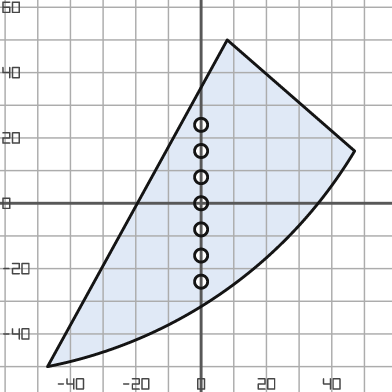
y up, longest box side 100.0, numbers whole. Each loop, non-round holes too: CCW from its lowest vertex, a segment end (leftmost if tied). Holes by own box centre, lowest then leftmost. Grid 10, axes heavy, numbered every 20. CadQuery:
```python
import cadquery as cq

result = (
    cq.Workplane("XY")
    .moveTo(-47.0, -50.0)
    .threePointArc((7.0, -27.0), (47.0, 16.0))
    .lineTo(8.0, 50.0)
    .close()
    .moveTo(0.0, -24.0)
    .circle(2.0)
    .moveTo(0.0, -16.0)
    .circle(2.0)
    .moveTo(0.0, -8.0)
    .circle(2.0)
    .moveTo(0.0, 0.0)
    .circle(2.0)
    .moveTo(0.0, 8.0)
    .circle(2.0)
    .moveTo(0.0, 16.0)
    .circle(2.0)
    .moveTo(0.0, 24.0)
    .circle(2.0)
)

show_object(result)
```